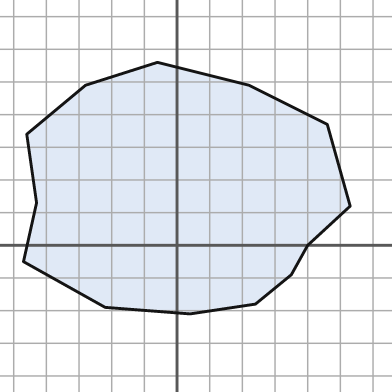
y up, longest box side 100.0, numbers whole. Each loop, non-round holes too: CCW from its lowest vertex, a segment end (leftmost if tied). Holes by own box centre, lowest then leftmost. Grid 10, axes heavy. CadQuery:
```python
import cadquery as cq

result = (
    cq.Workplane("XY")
    .moveTo(4.0, -21.0)
    .lineTo(24.0, -18.0)
    .lineTo(35.0, -9.0)
    .lineTo(40.0, 0.0)
    .lineTo(53.0, 12.0)
    .lineTo(46.0, 37.0)
    .lineTo(22.0, 49.0)
    .lineTo(-6.0, 56.0)
    .lineTo(-28.0, 49.0)
    .lineTo(-46.0, 34.0)
    .lineTo(-43.0, 13.0)
    .lineTo(-47.0, -5.0)
    .lineTo(-22.0, -19.0)
    .close()
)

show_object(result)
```